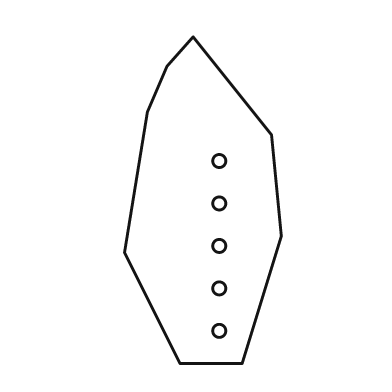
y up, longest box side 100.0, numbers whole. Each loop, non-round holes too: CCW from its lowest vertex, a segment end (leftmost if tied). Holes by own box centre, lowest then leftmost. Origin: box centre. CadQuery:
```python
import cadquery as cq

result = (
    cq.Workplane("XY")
    .moveTo(-7.0, -50.0)
    .lineTo(12.0, -50.0)
    .lineTo(24.0, -11.0)
    .lineTo(21.0, 20.0)
    .lineTo(-3.0, 50.0)
    .lineTo(-11.0, 41.0)
    .lineTo(-17.0, 27.0)
    .lineTo(-24.0, -16.0)
    .close()
    .moveTo(5.0, -40.0)
    .circle(2.0)
    .moveTo(5.0, -27.0)
    .circle(2.0)
    .moveTo(5.0, -14.0)
    .circle(2.0)
    .moveTo(5.0, -1.0)
    .circle(2.0)
    .moveTo(5.0, 12.0)
    .circle(2.0)
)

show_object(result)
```